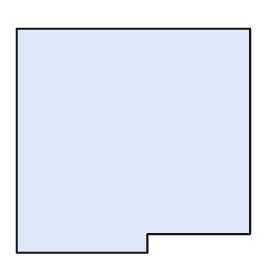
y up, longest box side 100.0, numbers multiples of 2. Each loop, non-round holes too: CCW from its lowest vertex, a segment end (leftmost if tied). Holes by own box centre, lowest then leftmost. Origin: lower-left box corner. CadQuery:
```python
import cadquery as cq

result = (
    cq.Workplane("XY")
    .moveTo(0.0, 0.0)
    .lineTo(56.0, 0.0)
    .lineTo(56.0, 8.0)
    .lineTo(100.0, 8.0)
    .lineTo(100.0, 96.0)
    .lineTo(0.0, 96.0)
    .close()
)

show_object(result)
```